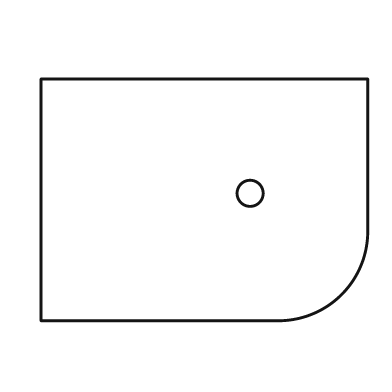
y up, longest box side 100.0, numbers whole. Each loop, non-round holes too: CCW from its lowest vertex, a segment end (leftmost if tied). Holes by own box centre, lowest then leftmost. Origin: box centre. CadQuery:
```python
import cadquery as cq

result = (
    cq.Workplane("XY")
    .moveTo(-50.0, -37.0)
    .lineTo(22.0, -37.0)
    .threePointArc((42.0, -29.0), (50.0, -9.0))
    .lineTo(50.0, 37.0)
    .lineTo(-50.0, 37.0)
    .close()
    .moveTo(14.0, 2.0)
    .circle(4.0)
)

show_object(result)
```